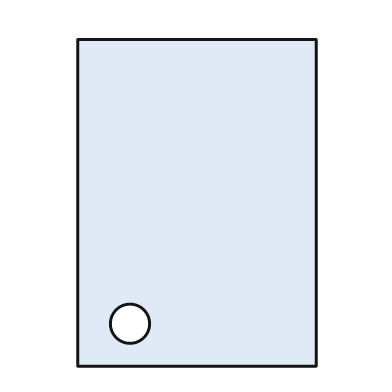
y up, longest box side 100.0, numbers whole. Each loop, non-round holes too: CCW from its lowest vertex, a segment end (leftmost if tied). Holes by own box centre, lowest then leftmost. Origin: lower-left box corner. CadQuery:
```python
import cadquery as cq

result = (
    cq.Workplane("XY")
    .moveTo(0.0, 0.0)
    .lineTo(73.0, 0.0)
    .lineTo(73.0, 100.0)
    .lineTo(0.0, 100.0)
    .close()
    .moveTo(16.0, 13.0)
    .circle(6.0)
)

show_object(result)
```